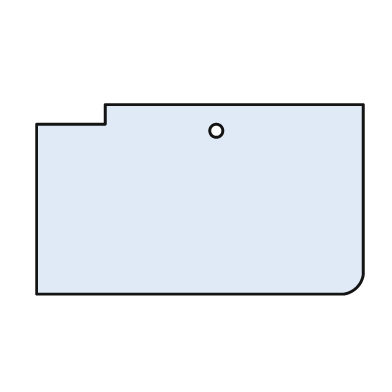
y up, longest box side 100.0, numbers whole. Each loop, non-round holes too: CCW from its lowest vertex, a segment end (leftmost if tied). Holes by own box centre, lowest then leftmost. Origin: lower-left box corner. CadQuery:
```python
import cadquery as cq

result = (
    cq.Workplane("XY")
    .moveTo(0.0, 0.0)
    .lineTo(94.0, 0.0)
    .threePointArc((98.0, 2.0), (100.0, 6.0))
    .lineTo(100.0, 58.0)
    .lineTo(21.0, 58.0)
    .lineTo(21.0, 52.0)
    .lineTo(0.0, 52.0)
    .close()
    .moveTo(55.0, 50.0)
    .circle(2.0)
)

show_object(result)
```